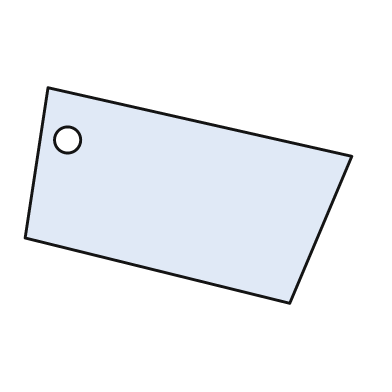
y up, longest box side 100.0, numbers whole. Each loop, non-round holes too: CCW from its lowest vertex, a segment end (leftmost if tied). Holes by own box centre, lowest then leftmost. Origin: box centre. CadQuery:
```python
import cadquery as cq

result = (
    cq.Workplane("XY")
    .moveTo(31.0, -33.0)
    .lineTo(50.0, 12.0)
    .lineTo(-43.0, 33.0)
    .lineTo(-50.0, -13.0)
    .close()
    .moveTo(-37.0, 17.0)
    .circle(4.0)
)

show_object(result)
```